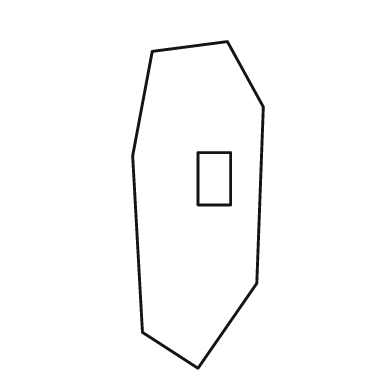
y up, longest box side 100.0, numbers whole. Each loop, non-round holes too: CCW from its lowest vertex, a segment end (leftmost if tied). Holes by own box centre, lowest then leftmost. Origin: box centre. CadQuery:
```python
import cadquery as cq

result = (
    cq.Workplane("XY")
    .moveTo(0.0, -50.0)
    .lineTo(18.0, -24.0)
    .lineTo(20.0, 30.0)
    .lineTo(9.0, 50.0)
    .lineTo(-14.0, 47.0)
    .lineTo(-20.0, 15.0)
    .lineTo(-17.0, -39.0)
    .close()
    .moveTo(0.0, 0.0)
    .lineTo(10.0, 0.0)
    .lineTo(10.0, 16.0)
    .lineTo(0.0, 16.0)
    .close()
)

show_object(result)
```